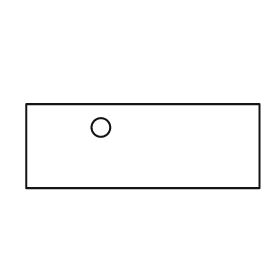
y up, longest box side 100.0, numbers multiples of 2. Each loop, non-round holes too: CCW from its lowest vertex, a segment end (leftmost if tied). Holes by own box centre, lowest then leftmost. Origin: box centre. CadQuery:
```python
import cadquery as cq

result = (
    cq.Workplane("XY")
    .moveTo(-50.0, -18.0)
    .lineTo(50.0, -18.0)
    .lineTo(50.0, 18.0)
    .lineTo(-50.0, 18.0)
    .close()
    .moveTo(-18.0, 8.0)
    .circle(4.0)
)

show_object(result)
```